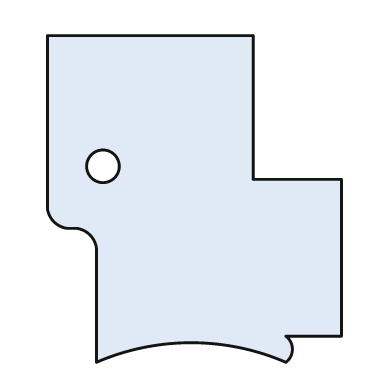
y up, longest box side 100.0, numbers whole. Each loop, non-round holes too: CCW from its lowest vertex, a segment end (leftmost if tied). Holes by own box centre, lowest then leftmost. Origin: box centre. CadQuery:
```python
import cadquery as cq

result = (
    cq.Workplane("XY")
    .moveTo(-30.0, -50.0)
    .threePointArc((-1.0, -44.0), (28.0, -50.0))
    .threePointArc((30.0, -46.0), (28.0, -42.0))
    .lineTo(45.0, -42.0)
    .lineTo(45.0, 6.0)
    .lineTo(18.0, 6.0)
    .lineTo(18.0, 50.0)
    .lineTo(-45.0, 50.0)
    .lineTo(-45.0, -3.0)
    .threePointArc((-43.0, -7.0), (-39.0, -9.0))
    .lineTo(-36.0, -9.0)
    .threePointArc((-32.0, -11.0), (-30.0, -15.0))
    .close()
    .moveTo(-28.0, 10.0)
    .circle(5.0)
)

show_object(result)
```